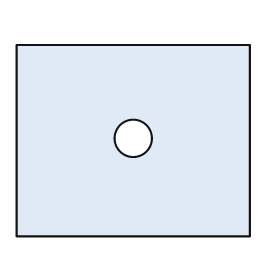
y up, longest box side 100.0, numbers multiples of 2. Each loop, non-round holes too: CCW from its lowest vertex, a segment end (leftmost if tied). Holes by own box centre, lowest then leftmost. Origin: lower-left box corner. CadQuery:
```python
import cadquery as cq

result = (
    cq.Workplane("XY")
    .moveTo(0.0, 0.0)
    .lineTo(100.0, 0.0)
    .lineTo(100.0, 82.0)
    .lineTo(0.0, 82.0)
    .close()
    .moveTo(50.0, 42.0)
    .circle(8.0)
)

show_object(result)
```